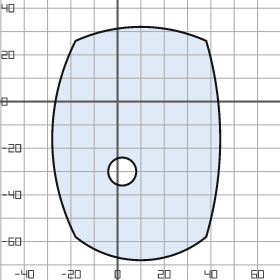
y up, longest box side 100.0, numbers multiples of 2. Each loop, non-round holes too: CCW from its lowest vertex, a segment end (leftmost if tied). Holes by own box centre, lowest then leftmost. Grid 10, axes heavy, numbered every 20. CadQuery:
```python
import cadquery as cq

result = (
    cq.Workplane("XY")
    .moveTo(-18.0, -58.0)
    .threePointArc((10.0, -68.0), (38.0, -58.0))
    .threePointArc((44.0, -16.0), (38.0, 26.0))
    .threePointArc((10.0, 32.0), (-18.0, 26.0))
    .threePointArc((-28.0, -16.0), (-18.0, -58.0))
    .close()
    .moveTo(2.0, -30.0)
    .circle(6.0)
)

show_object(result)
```